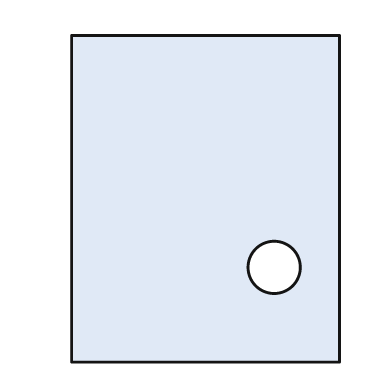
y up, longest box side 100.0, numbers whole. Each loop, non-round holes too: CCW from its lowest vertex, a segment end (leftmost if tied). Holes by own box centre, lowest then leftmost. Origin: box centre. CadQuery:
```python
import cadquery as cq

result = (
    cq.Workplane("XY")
    .moveTo(-41.0, -50.0)
    .lineTo(41.0, -50.0)
    .lineTo(41.0, 50.0)
    .lineTo(-41.0, 50.0)
    .close()
    .moveTo(21.0, -21.0)
    .circle(8.0)
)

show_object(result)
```